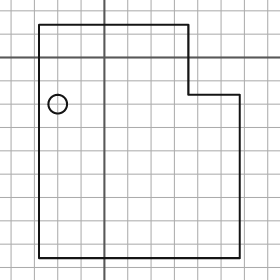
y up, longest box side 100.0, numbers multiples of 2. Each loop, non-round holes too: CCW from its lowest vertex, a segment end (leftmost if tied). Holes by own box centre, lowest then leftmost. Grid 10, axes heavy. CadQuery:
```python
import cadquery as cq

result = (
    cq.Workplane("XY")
    .moveTo(-28.0, -86.0)
    .lineTo(58.0, -86.0)
    .lineTo(58.0, -16.0)
    .lineTo(36.0, -16.0)
    .lineTo(36.0, 14.0)
    .lineTo(-28.0, 14.0)
    .close()
    .moveTo(-20.0, -20.0)
    .circle(4.0)
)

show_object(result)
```